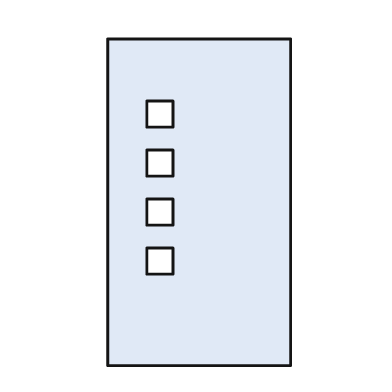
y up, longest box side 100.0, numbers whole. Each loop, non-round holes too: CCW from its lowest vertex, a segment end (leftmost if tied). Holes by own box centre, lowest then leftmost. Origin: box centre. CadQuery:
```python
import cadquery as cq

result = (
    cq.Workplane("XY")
    .moveTo(-28.0, -50.0)
    .lineTo(28.0, -50.0)
    .lineTo(28.0, 50.0)
    .lineTo(-28.0, 50.0)
    .close()
    .moveTo(-16.0, -22.0)
    .lineTo(-8.0, -22.0)
    .lineTo(-8.0, -14.0)
    .lineTo(-16.0, -14.0)
    .close()
    .moveTo(-16.0, -7.0)
    .lineTo(-8.0, -7.0)
    .lineTo(-8.0, 1.0)
    .lineTo(-16.0, 1.0)
    .close()
    .moveTo(-16.0, 8.0)
    .lineTo(-8.0, 8.0)
    .lineTo(-8.0, 16.0)
    .lineTo(-16.0, 16.0)
    .close()
    .moveTo(-16.0, 23.0)
    .lineTo(-8.0, 23.0)
    .lineTo(-8.0, 31.0)
    .lineTo(-16.0, 31.0)
    .close()
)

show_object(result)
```